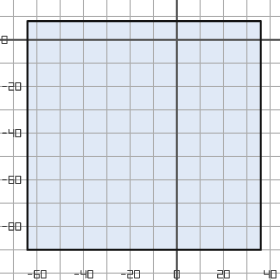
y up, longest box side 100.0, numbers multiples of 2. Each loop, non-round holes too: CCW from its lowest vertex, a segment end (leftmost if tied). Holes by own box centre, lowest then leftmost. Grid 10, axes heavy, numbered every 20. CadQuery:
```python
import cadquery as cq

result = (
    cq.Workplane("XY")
    .moveTo(-64.0, -90.0)
    .lineTo(36.0, -90.0)
    .lineTo(36.0, 8.0)
    .lineTo(-64.0, 8.0)
    .close()
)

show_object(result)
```